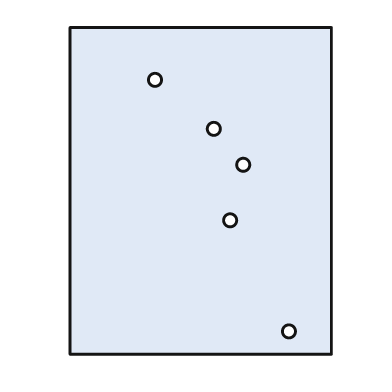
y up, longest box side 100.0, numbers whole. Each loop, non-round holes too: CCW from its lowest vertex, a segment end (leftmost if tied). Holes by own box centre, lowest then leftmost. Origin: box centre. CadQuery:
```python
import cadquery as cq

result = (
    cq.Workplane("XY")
    .moveTo(-40.0, -50.0)
    .lineTo(40.0, -50.0)
    .lineTo(40.0, 50.0)
    .lineTo(-40.0, 50.0)
    .close()
    .moveTo(27.0, -43.0)
    .circle(2.0)
    .moveTo(9.0, -9.0)
    .circle(2.0)
    .moveTo(13.0, 8.0)
    .circle(2.0)
    .moveTo(4.0, 19.0)
    .circle(2.0)
    .moveTo(-14.0, 34.0)
    .circle(2.0)
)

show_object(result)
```